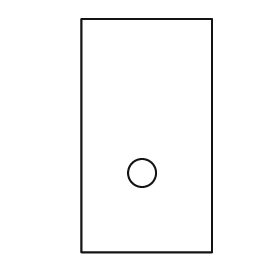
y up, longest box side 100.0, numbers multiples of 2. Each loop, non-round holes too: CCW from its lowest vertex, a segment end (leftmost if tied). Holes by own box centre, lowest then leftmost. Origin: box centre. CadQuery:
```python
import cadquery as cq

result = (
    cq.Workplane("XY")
    .moveTo(-28.0, -50.0)
    .lineTo(28.0, -50.0)
    .lineTo(28.0, 50.0)
    .lineTo(-28.0, 50.0)
    .close()
    .moveTo(-2.0, -16.0)
    .circle(6.0)
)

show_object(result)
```